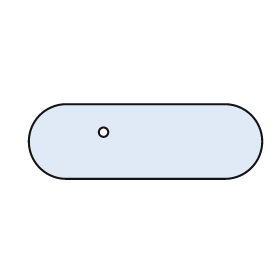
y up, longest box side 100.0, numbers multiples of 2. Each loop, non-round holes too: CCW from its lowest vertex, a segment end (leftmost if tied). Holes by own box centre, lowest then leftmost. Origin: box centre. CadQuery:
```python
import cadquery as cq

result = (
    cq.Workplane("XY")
    .moveTo(-34.0, -16.0)
    .lineTo(34.0, -16.0)
    .threePointArc((50.0, 0.0), (34.0, 16.0))
    .lineTo(-34.0, 16.0)
    .threePointArc((-50.0, 0.0), (-34.0, -16.0))
    .close()
    .moveTo(-18.0, 4.0)
    .circle(2.0)
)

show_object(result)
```